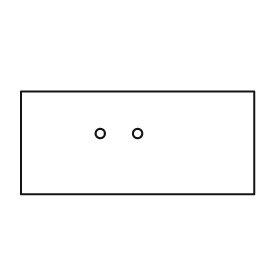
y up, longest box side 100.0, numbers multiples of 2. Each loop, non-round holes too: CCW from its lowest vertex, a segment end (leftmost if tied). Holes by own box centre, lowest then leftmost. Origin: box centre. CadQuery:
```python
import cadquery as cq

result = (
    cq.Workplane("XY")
    .moveTo(-50.0, -22.0)
    .lineTo(50.0, -22.0)
    .lineTo(50.0, 22.0)
    .lineTo(-50.0, 22.0)
    .close()
    .moveTo(-16.0, 4.0)
    .circle(2.0)
    .moveTo(0.0, 4.0)
    .circle(2.0)
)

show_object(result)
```